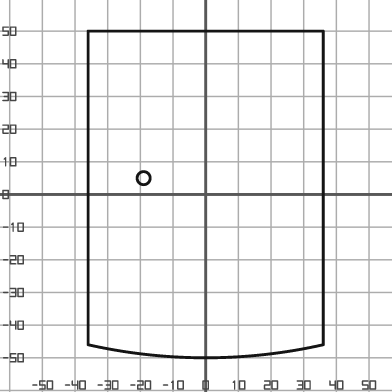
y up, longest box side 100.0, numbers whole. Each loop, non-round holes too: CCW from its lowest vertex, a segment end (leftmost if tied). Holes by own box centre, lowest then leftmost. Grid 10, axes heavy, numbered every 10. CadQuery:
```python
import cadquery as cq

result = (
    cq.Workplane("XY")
    .moveTo(-36.0, -46.0)
    .threePointArc((0.0, -50.0), (36.0, -46.0))
    .lineTo(36.0, 50.0)
    .lineTo(-36.0, 50.0)
    .close()
    .moveTo(-19.0, 5.0)
    .circle(2.0)
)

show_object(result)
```